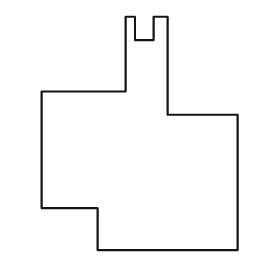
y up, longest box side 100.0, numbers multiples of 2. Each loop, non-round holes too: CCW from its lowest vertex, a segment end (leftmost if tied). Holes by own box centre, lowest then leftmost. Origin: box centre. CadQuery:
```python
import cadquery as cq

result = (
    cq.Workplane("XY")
    .moveTo(-18.0, -50.0)
    .lineTo(42.0, -50.0)
    .lineTo(42.0, 8.0)
    .lineTo(12.0, 8.0)
    .lineTo(12.0, 50.0)
    .lineTo(6.0, 50.0)
    .lineTo(6.0, 40.0)
    .lineTo(-2.0, 40.0)
    .lineTo(-2.0, 50.0)
    .lineTo(-6.0, 50.0)
    .lineTo(-6.0, 18.0)
    .lineTo(-42.0, 18.0)
    .lineTo(-42.0, -32.0)
    .lineTo(-18.0, -32.0)
    .close()
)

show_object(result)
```